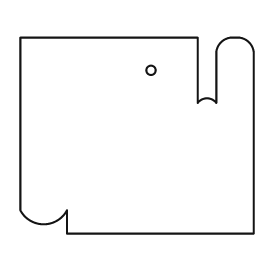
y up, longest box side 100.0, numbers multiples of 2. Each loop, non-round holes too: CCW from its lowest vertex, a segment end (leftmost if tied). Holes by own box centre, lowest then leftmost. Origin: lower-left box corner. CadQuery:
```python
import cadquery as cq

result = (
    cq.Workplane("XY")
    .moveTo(20.0, 0.0)
    .lineTo(100.0, 0.0)
    .lineTo(100.0, 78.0)
    .threePointArc((98.0, 82.0), (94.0, 84.0))
    .lineTo(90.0, 84.0)
    .threePointArc((86.0, 82.0), (84.0, 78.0))
    .lineTo(84.0, 56.0)
    .threePointArc((80.0, 58.0), (76.0, 56.0))
    .lineTo(76.0, 84.0)
    .lineTo(0.0, 84.0)
    .lineTo(0.0, 10.0)
    .threePointArc((10.0, 4.0), (20.0, 10.0))
    .close()
    .moveTo(56.0, 70.0)
    .circle(2.0)
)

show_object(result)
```